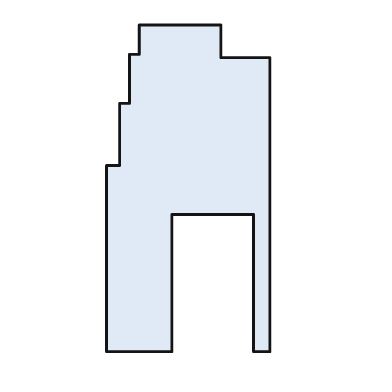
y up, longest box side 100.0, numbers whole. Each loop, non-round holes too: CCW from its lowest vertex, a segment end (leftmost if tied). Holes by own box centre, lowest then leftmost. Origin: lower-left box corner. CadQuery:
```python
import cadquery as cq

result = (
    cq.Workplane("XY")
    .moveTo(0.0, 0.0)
    .lineTo(20.0, 0.0)
    .lineTo(20.0, 42.0)
    .lineTo(45.0, 42.0)
    .lineTo(45.0, 0.0)
    .lineTo(50.0, 0.0)
    .lineTo(50.0, 90.0)
    .lineTo(35.0, 90.0)
    .lineTo(35.0, 100.0)
    .lineTo(10.0, 100.0)
    .lineTo(10.0, 91.0)
    .lineTo(7.0, 91.0)
    .lineTo(7.0, 76.0)
    .lineTo(4.0, 76.0)
    .lineTo(4.0, 57.0)
    .lineTo(0.0, 57.0)
    .close()
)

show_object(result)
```